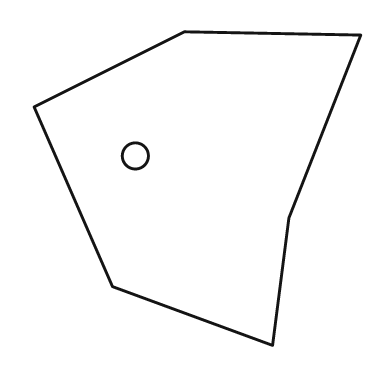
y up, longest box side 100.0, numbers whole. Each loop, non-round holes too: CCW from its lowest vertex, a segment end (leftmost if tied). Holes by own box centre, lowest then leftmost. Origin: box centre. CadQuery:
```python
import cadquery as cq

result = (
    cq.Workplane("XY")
    .moveTo(23.0, -48.0)
    .lineTo(28.0, -9.0)
    .lineTo(50.0, 47.0)
    .lineTo(-4.0, 48.0)
    .lineTo(-50.0, 25.0)
    .lineTo(-26.0, -30.0)
    .close()
    .moveTo(-19.0, 10.0)
    .circle(4.0)
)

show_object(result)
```